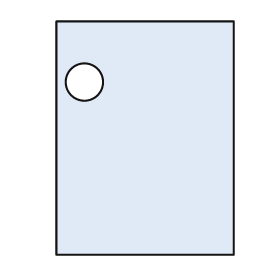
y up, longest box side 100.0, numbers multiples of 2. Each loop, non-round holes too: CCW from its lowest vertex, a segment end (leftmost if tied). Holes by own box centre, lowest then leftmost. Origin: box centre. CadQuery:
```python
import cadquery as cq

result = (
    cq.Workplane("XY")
    .moveTo(-38.0, -50.0)
    .lineTo(38.0, -50.0)
    .lineTo(38.0, 50.0)
    .lineTo(-38.0, 50.0)
    .close()
    .moveTo(-26.0, 24.0)
    .circle(8.0)
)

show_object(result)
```